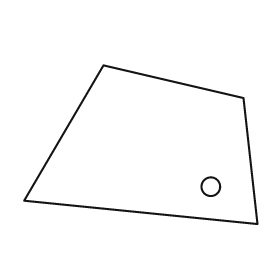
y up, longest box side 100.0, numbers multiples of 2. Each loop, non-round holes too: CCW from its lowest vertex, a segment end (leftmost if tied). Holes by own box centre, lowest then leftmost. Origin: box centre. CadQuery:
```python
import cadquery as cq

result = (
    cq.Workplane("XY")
    .moveTo(50.0, -34.0)
    .lineTo(44.0, 20.0)
    .lineTo(-16.0, 34.0)
    .lineTo(-50.0, -24.0)
    .close()
    .moveTo(30.0, -18.0)
    .circle(4.0)
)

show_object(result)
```